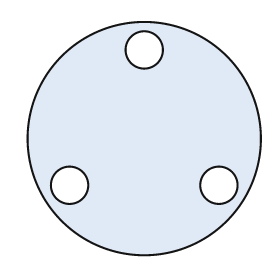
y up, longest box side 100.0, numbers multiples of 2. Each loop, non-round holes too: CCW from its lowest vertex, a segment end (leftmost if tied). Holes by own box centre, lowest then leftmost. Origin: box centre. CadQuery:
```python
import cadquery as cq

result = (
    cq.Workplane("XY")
    .moveTo(0.0, 0.0)
    .circle(50.0)
    .moveTo(-32.0, -20.0)
    .circle(8.0)
    .moveTo(32.0, -20.0)
    .circle(8.0)
    .moveTo(0.0, 38.0)
    .circle(8.0)
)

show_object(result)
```